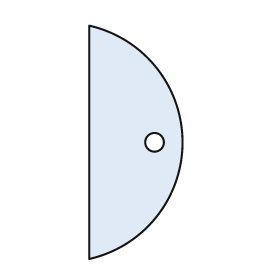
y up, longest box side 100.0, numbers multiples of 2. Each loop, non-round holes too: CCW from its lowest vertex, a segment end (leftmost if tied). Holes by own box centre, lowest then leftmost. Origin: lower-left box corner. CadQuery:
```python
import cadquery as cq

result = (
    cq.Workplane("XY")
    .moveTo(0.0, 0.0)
    .threePointArc((40.0, 50.0), (0.0, 100.0))
    .close()
    .moveTo(28.0, 50.0)
    .circle(4.0)
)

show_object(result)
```